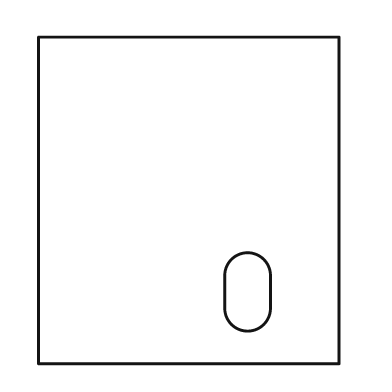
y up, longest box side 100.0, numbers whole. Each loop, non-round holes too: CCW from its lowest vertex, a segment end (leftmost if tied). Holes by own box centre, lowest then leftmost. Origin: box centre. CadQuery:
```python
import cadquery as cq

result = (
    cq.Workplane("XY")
    .moveTo(-46.0, -50.0)
    .lineTo(46.0, -50.0)
    .lineTo(46.0, 50.0)
    .lineTo(-46.0, 50.0)
    .close()
    .moveTo(11.0, -33.0)
    .threePointArc((18.0, -40.0), (25.0, -33.0))
    .lineTo(25.0, -23.0)
    .threePointArc((18.0, -16.0), (11.0, -23.0))
    .close()
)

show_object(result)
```